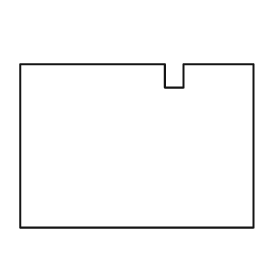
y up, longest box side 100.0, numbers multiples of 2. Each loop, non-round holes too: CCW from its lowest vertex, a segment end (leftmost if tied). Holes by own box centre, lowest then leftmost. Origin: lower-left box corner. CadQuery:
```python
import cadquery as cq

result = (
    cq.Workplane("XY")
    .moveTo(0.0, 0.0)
    .lineTo(100.0, 0.0)
    .lineTo(100.0, 70.0)
    .lineTo(70.0, 70.0)
    .lineTo(70.0, 60.0)
    .lineTo(62.0, 60.0)
    .lineTo(62.0, 70.0)
    .lineTo(0.0, 70.0)
    .close()
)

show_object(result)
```